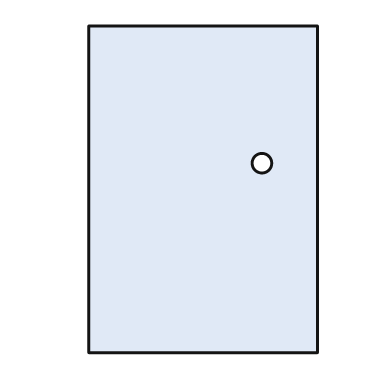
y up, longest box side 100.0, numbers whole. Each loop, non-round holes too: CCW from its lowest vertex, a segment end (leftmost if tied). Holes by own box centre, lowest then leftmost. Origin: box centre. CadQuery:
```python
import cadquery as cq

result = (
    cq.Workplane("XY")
    .moveTo(-35.0, -50.0)
    .lineTo(35.0, -50.0)
    .lineTo(35.0, 50.0)
    .lineTo(-35.0, 50.0)
    .close()
    .moveTo(18.0, 8.0)
    .circle(3.0)
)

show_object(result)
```